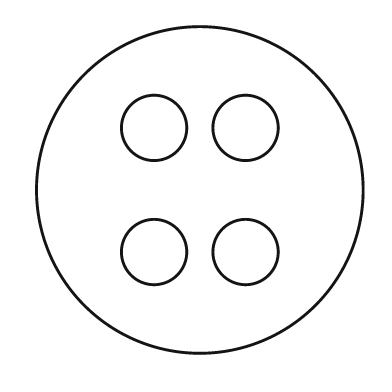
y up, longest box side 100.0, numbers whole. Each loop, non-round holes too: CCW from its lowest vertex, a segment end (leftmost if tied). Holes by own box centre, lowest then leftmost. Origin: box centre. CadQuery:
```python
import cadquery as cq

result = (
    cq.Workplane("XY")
    .moveTo(0.0, 0.0)
    .circle(50.0)
    .moveTo(-14.0, -19.0)
    .circle(10.0)
    .moveTo(14.0, -19.0)
    .circle(10.0)
    .moveTo(-14.0, 19.0)
    .circle(10.0)
    .moveTo(14.0, 19.0)
    .circle(10.0)
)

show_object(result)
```